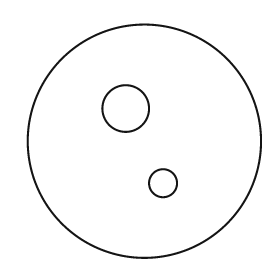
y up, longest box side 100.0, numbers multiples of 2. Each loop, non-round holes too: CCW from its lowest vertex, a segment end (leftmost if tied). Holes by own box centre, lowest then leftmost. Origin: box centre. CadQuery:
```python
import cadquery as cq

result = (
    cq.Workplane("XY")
    .moveTo(0.0, 0.0)
    .circle(50.0)
    .moveTo(8.0, -18.0)
    .circle(6.0)
    .moveTo(-8.0, 14.0)
    .circle(10.0)
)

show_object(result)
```